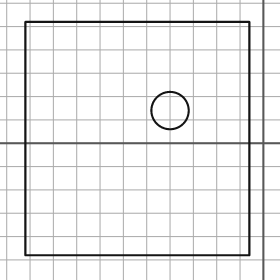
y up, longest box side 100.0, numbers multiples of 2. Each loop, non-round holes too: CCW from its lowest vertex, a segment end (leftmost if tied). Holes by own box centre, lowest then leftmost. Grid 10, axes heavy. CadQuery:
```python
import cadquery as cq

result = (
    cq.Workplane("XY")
    .moveTo(-102.0, -48.0)
    .lineTo(-6.0, -48.0)
    .lineTo(-6.0, 52.0)
    .lineTo(-102.0, 52.0)
    .close()
    .moveTo(-40.0, 14.0)
    .circle(8.0)
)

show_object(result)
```